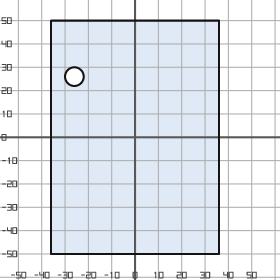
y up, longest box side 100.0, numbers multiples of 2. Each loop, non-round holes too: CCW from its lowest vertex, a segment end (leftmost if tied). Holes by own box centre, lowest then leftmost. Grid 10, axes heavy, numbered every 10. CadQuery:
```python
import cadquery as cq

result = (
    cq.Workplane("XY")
    .moveTo(-36.0, -50.0)
    .lineTo(36.0, -50.0)
    .lineTo(36.0, 50.0)
    .lineTo(-36.0, 50.0)
    .close()
    .moveTo(-26.0, 26.0)
    .circle(4.0)
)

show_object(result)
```